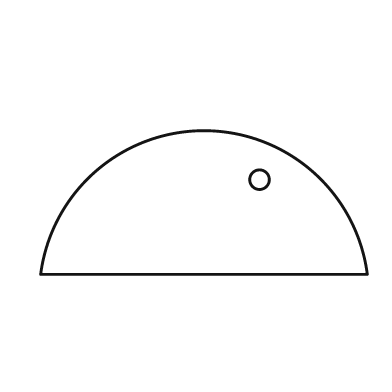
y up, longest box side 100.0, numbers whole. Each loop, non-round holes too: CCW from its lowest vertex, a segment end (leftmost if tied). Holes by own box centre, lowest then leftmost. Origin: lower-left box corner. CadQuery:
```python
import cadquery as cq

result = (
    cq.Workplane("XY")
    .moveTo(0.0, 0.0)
    .lineTo(100.0, 0.0)
    .threePointArc((50.0, 44.0), (0.0, 0.0))
    .close()
    .moveTo(67.0, 29.0)
    .circle(3.0)
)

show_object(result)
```